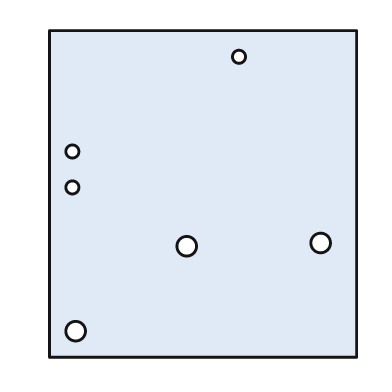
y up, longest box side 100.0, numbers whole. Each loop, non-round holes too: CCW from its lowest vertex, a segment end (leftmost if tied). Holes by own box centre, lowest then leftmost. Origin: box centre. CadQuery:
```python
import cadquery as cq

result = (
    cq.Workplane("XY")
    .moveTo(-47.0, -50.0)
    .lineTo(47.0, -50.0)
    .lineTo(47.0, 50.0)
    .lineTo(-47.0, 50.0)
    .close()
    .moveTo(-39.0, -42.0)
    .circle(3.0)
    .moveTo(-5.0, -16.0)
    .circle(3.0)
    .moveTo(36.0, -15.0)
    .circle(3.0)
    .moveTo(-40.0, 2.0)
    .circle(2.0)
    .moveTo(-40.0, 13.0)
    .circle(2.0)
    .moveTo(11.0, 42.0)
    .circle(2.0)
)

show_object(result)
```